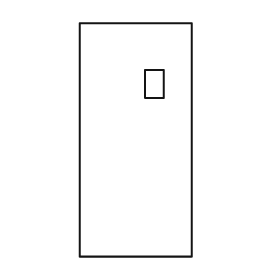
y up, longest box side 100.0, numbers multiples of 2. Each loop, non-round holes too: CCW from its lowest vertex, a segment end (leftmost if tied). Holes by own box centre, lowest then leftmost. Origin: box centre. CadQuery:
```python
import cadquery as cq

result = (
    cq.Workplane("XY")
    .moveTo(-24.0, -50.0)
    .lineTo(24.0, -50.0)
    .lineTo(24.0, 50.0)
    .lineTo(-24.0, 50.0)
    .close()
    .moveTo(4.0, 18.0)
    .lineTo(12.0, 18.0)
    .lineTo(12.0, 30.0)
    .lineTo(4.0, 30.0)
    .close()
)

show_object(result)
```